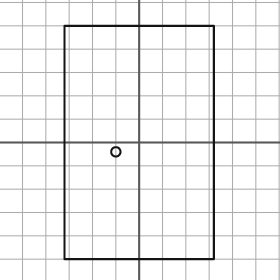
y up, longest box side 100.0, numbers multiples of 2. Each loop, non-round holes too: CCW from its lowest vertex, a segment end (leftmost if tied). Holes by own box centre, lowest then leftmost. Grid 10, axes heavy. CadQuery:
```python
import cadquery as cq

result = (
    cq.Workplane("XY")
    .moveTo(-32.0, -50.0)
    .lineTo(32.0, -50.0)
    .lineTo(32.0, 50.0)
    .lineTo(-32.0, 50.0)
    .close()
    .moveTo(-10.0, -4.0)
    .circle(2.0)
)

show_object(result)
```